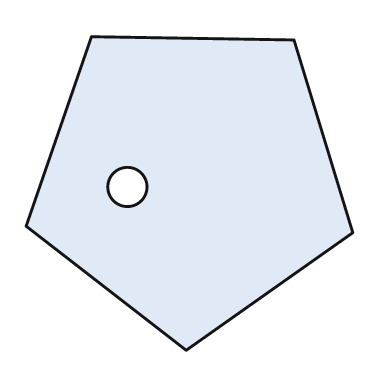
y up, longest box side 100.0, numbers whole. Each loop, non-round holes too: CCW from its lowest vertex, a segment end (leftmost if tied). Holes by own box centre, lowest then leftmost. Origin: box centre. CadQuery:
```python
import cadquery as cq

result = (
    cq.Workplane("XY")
    .moveTo(-1.0, -48.0)
    .lineTo(50.0, -12.0)
    .lineTo(32.0, 47.0)
    .lineTo(-30.0, 48.0)
    .lineTo(-50.0, -10.0)
    .close()
    .moveTo(-19.0, 2.0)
    .circle(6.0)
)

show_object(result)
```